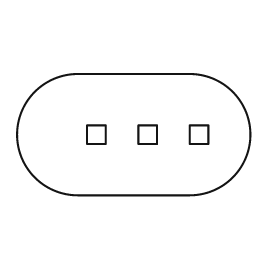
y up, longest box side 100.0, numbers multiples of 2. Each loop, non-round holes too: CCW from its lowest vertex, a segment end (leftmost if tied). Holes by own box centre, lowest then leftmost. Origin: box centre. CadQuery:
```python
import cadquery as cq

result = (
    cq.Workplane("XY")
    .moveTo(-24.0, -26.0)
    .lineTo(24.0, -26.0)
    .threePointArc((50.0, 0.0), (24.0, 26.0))
    .lineTo(-24.0, 26.0)
    .threePointArc((-50.0, 0.0), (-24.0, -26.0))
    .close()
    .moveTo(-20.0, -4.0)
    .lineTo(-12.0, -4.0)
    .lineTo(-12.0, 4.0)
    .lineTo(-20.0, 4.0)
    .close()
    .moveTo(2.0, -4.0)
    .lineTo(10.0, -4.0)
    .lineTo(10.0, 4.0)
    .lineTo(2.0, 4.0)
    .close()
    .moveTo(24.0, -4.0)
    .lineTo(32.0, -4.0)
    .lineTo(32.0, 4.0)
    .lineTo(24.0, 4.0)
    .close()
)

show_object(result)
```